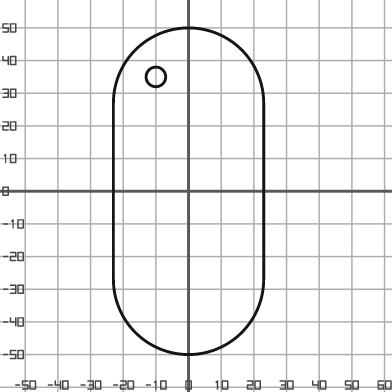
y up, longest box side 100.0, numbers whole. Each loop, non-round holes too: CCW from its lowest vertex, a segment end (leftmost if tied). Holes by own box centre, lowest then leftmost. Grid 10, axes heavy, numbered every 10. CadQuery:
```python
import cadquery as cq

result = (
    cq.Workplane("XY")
    .moveTo(-23.0, -27.0)
    .threePointArc((0.0, -50.0), (23.0, -27.0))
    .lineTo(23.0, 27.0)
    .threePointArc((0.0, 50.0), (-23.0, 27.0))
    .close()
    .moveTo(-10.0, 35.0)
    .circle(3.0)
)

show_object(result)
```